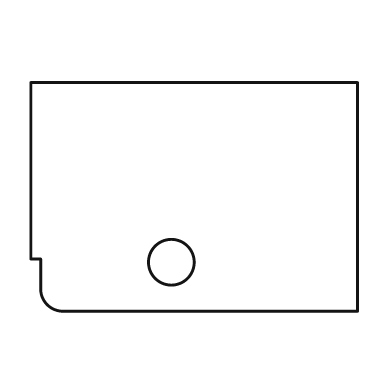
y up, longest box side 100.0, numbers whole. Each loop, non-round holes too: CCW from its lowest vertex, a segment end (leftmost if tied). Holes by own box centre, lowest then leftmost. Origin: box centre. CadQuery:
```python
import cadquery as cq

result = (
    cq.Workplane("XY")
    .moveTo(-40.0, -35.0)
    .lineTo(50.0, -35.0)
    .lineTo(50.0, 35.0)
    .lineTo(-50.0, 35.0)
    .lineTo(-50.0, -19.0)
    .lineTo(-47.0, -19.0)
    .lineTo(-47.0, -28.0)
    .threePointArc((-45.0, -33.0), (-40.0, -35.0))
    .close()
    .moveTo(-7.0, -20.0)
    .circle(7.0)
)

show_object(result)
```